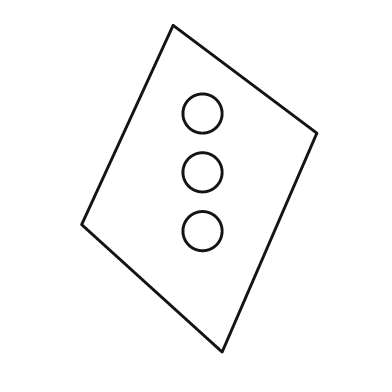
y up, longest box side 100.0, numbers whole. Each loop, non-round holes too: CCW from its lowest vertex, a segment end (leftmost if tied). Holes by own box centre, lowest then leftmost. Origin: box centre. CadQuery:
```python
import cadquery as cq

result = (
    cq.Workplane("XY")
    .moveTo(7.0, -50.0)
    .lineTo(36.0, 17.0)
    .lineTo(-8.0, 50.0)
    .lineTo(-36.0, -11.0)
    .close()
    .moveTo(1.0, -13.0)
    .circle(6.0)
    .moveTo(1.0, 5.0)
    .circle(6.0)
    .moveTo(1.0, 23.0)
    .circle(6.0)
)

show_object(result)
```